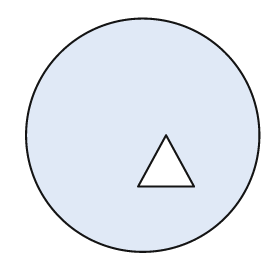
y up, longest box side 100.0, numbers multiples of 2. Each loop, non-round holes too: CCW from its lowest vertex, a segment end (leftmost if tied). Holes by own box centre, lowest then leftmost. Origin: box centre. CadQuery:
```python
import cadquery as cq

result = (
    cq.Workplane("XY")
    .moveTo(0.0, 0.0)
    .circle(50.0)
    .moveTo(-2.0, -22.0)
    .lineTo(22.0, -22.0)
    .lineTo(10.0, 0.0)
    .close()
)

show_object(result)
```